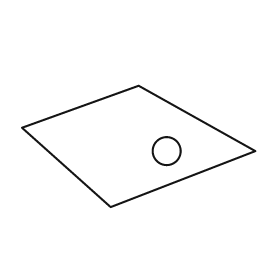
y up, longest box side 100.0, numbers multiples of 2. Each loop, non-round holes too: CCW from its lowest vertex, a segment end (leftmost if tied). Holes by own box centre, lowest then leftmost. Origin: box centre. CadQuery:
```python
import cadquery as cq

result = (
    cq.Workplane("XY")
    .moveTo(-12.0, -26.0)
    .lineTo(50.0, -2.0)
    .lineTo(0.0, 26.0)
    .lineTo(-50.0, 8.0)
    .close()
    .moveTo(12.0, -2.0)
    .circle(6.0)
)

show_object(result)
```